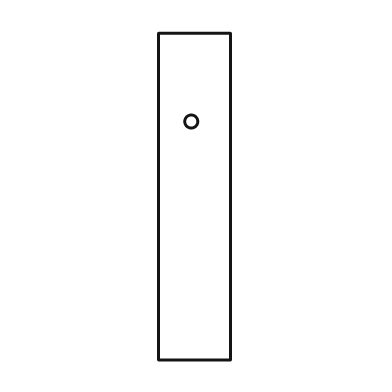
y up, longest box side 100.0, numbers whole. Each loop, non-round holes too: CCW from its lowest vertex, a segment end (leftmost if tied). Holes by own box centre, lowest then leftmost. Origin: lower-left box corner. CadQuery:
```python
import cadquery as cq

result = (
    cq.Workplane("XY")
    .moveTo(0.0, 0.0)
    .lineTo(22.0, 0.0)
    .lineTo(22.0, 100.0)
    .lineTo(0.0, 100.0)
    .close()
    .moveTo(10.0, 73.0)
    .circle(2.0)
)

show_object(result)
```